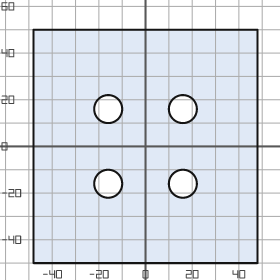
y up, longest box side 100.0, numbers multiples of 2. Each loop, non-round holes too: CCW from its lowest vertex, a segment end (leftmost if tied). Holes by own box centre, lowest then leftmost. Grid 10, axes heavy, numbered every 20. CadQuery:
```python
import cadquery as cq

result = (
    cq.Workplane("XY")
    .moveTo(-48.0, -50.0)
    .lineTo(48.0, -50.0)
    .lineTo(48.0, 50.0)
    .lineTo(-48.0, 50.0)
    .close()
    .moveTo(-16.0, -16.0)
    .circle(6.0)
    .moveTo(16.0, -16.0)
    .circle(6.0)
    .moveTo(-16.0, 16.0)
    .circle(6.0)
    .moveTo(16.0, 16.0)
    .circle(6.0)
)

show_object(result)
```